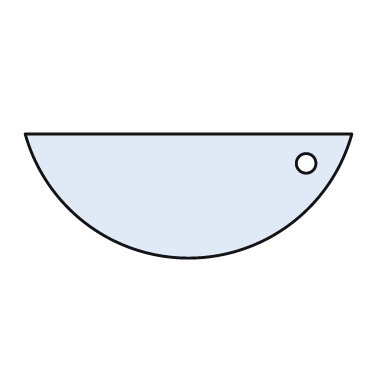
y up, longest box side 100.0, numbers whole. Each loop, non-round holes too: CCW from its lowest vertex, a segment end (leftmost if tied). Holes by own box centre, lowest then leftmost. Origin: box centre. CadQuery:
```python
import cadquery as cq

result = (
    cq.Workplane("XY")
    .moveTo(-50.0, 19.0)
    .threePointArc((0.0, -19.0), (50.0, 19.0))
    .close()
    .moveTo(36.0, 10.0)
    .circle(3.0)
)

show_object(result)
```